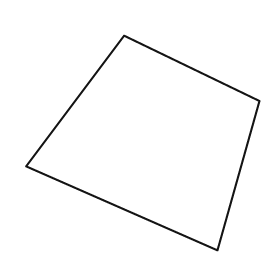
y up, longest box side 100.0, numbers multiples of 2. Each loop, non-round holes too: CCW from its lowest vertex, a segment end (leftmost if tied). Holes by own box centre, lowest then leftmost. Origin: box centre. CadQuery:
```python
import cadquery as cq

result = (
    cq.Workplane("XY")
    .moveTo(32.0, -46.0)
    .lineTo(50.0, 18.0)
    .lineTo(-8.0, 46.0)
    .lineTo(-50.0, -10.0)
    .close()
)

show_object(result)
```